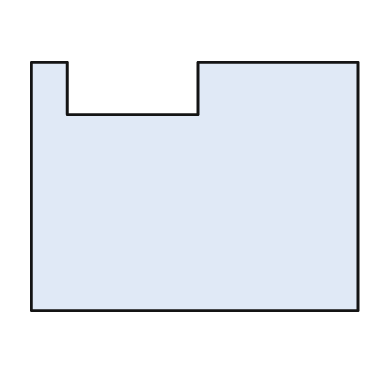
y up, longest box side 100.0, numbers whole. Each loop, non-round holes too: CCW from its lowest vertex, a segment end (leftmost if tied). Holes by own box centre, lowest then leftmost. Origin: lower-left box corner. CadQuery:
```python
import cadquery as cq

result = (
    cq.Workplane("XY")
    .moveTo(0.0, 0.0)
    .lineTo(100.0, 0.0)
    .lineTo(100.0, 76.0)
    .lineTo(51.0, 76.0)
    .lineTo(51.0, 60.0)
    .lineTo(11.0, 60.0)
    .lineTo(11.0, 76.0)
    .lineTo(0.0, 76.0)
    .close()
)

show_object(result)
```